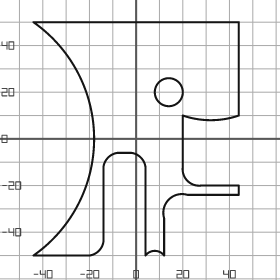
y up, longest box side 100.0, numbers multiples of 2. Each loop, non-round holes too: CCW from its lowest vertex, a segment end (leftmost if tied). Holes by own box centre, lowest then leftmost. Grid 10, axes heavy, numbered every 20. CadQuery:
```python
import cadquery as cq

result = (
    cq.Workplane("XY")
    .moveTo(-44.0, -50.0)
    .lineTo(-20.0, -50.0)
    .threePointArc((-16.0, -48.0), (-14.0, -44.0))
    .lineTo(-14.0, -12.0)
    .threePointArc((-12.0, -8.0), (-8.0, -6.0))
    .lineTo(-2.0, -6.0)
    .threePointArc((2.0, -8.0), (4.0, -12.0))
    .lineTo(4.0, -50.0)
    .threePointArc((8.0, -48.0), (12.0, -50.0))
    .lineTo(12.0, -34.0)
    .threePointArc((14.0, -26.0), (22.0, -24.0))
    .lineTo(44.0, -24.0)
    .lineTo(44.0, -20.0)
    .lineTo(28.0, -20.0)
    .threePointArc((22.0, -18.0), (20.0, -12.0))
    .lineTo(20.0, 10.0)
    .threePointArc((32.0, 8.0), (44.0, 10.0))
    .lineTo(44.0, 50.0)
    .lineTo(-44.0, 50.0)
    .threePointArc((-18.0, 0.0), (-44.0, -50.0))
    .close()
    .moveTo(14.0, 20.0)
    .circle(6.0)
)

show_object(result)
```